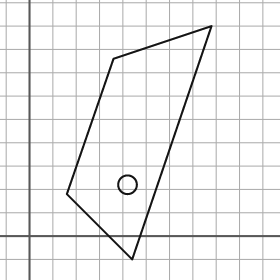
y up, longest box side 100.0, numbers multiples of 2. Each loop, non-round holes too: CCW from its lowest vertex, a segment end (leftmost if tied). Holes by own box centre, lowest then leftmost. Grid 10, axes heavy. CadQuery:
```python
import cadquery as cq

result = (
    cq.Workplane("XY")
    .moveTo(44.0, -10.0)
    .lineTo(78.0, 90.0)
    .lineTo(36.0, 76.0)
    .lineTo(16.0, 18.0)
    .close()
    .moveTo(42.0, 22.0)
    .circle(4.0)
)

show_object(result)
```